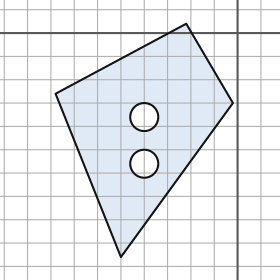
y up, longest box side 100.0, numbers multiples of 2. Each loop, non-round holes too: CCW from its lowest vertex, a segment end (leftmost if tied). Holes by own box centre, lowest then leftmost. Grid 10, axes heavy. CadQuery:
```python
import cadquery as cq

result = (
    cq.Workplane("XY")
    .moveTo(-50.0, -96.0)
    .lineTo(-2.0, -30.0)
    .lineTo(-22.0, 4.0)
    .lineTo(-78.0, -26.0)
    .close()
    .moveTo(-40.0, -56.0)
    .circle(6.0)
    .moveTo(-40.0, -36.0)
    .circle(6.0)
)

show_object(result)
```